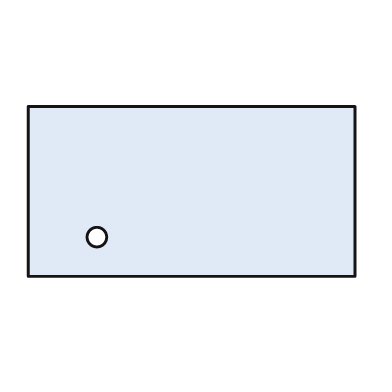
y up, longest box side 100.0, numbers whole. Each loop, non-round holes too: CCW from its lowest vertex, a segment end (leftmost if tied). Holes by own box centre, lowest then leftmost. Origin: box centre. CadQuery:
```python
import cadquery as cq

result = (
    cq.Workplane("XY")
    .moveTo(-50.0, -26.0)
    .lineTo(50.0, -26.0)
    .lineTo(50.0, 26.0)
    .lineTo(-50.0, 26.0)
    .close()
    .moveTo(-29.0, -14.0)
    .circle(3.0)
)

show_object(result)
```